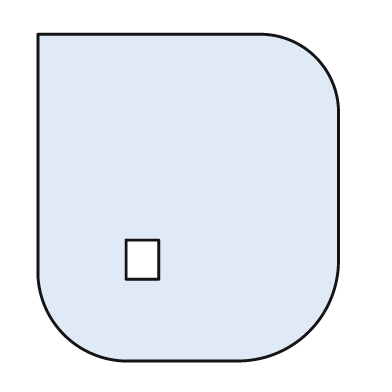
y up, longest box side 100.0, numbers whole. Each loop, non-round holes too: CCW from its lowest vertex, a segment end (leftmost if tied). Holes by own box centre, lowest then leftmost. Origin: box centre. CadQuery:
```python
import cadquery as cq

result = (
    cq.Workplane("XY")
    .moveTo(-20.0, -50.0)
    .lineTo(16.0, -50.0)
    .threePointArc((37.0, -41.0), (46.0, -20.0))
    .lineTo(46.0, 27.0)
    .threePointArc((39.0, 43.0), (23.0, 50.0))
    .lineTo(-46.0, 50.0)
    .lineTo(-46.0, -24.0)
    .threePointArc((-38.0, -42.0), (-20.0, -50.0))
    .close()
    .moveTo(-19.0, -25.0)
    .lineTo(-9.0, -25.0)
    .lineTo(-9.0, -13.0)
    .lineTo(-19.0, -13.0)
    .close()
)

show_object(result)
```